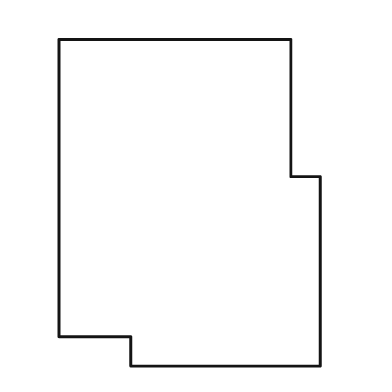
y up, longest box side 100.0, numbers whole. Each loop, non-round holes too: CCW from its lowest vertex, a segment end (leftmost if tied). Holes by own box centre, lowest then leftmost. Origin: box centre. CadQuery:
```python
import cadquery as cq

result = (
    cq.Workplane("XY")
    .moveTo(-18.0, -50.0)
    .lineTo(40.0, -50.0)
    .lineTo(40.0, 8.0)
    .lineTo(31.0, 8.0)
    .lineTo(31.0, 50.0)
    .lineTo(-40.0, 50.0)
    .lineTo(-40.0, -41.0)
    .lineTo(-18.0, -41.0)
    .close()
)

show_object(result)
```